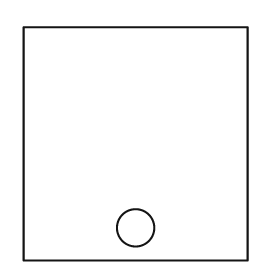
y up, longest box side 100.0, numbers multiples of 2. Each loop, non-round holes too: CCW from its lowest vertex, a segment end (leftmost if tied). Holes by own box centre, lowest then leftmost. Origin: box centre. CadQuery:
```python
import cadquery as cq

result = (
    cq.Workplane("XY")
    .moveTo(-48.0, -50.0)
    .lineTo(48.0, -50.0)
    .lineTo(48.0, 50.0)
    .lineTo(-48.0, 50.0)
    .close()
    .moveTo(0.0, -36.0)
    .circle(8.0)
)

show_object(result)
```